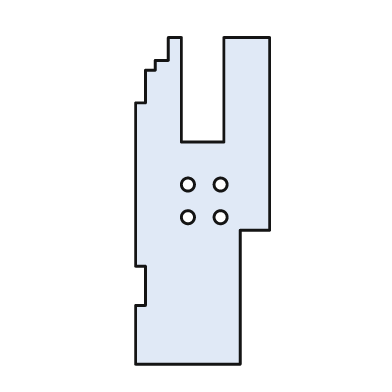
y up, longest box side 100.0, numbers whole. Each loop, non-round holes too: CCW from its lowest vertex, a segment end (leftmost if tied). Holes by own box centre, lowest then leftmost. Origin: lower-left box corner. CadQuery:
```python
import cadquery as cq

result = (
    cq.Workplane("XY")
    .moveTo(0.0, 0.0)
    .lineTo(32.0, 0.0)
    .lineTo(32.0, 41.0)
    .lineTo(41.0, 41.0)
    .lineTo(41.0, 100.0)
    .lineTo(27.0, 100.0)
    .lineTo(27.0, 68.0)
    .lineTo(14.0, 68.0)
    .lineTo(14.0, 100.0)
    .lineTo(10.0, 100.0)
    .lineTo(10.0, 93.0)
    .lineTo(6.0, 93.0)
    .lineTo(6.0, 90.0)
    .lineTo(3.0, 90.0)
    .lineTo(3.0, 80.0)
    .lineTo(0.0, 80.0)
    .lineTo(0.0, 30.0)
    .lineTo(3.0, 30.0)
    .lineTo(3.0, 18.0)
    .lineTo(0.0, 18.0)
    .close()
    .moveTo(16.0, 45.0)
    .circle(2.0)
    .moveTo(26.0, 45.0)
    .circle(2.0)
    .moveTo(16.0, 55.0)
    .circle(2.0)
    .moveTo(26.0, 55.0)
    .circle(2.0)
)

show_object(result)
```